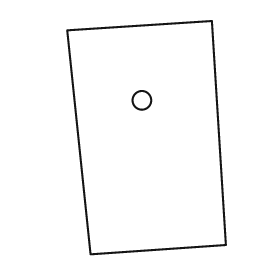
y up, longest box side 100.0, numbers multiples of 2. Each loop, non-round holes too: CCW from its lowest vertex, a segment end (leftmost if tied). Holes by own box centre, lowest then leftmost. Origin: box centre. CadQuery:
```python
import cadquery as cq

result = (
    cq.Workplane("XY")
    .moveTo(-24.0, -50.0)
    .lineTo(34.0, -46.0)
    .lineTo(28.0, 50.0)
    .lineTo(-34.0, 46.0)
    .close()
    .moveTo(-2.0, 16.0)
    .circle(4.0)
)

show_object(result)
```